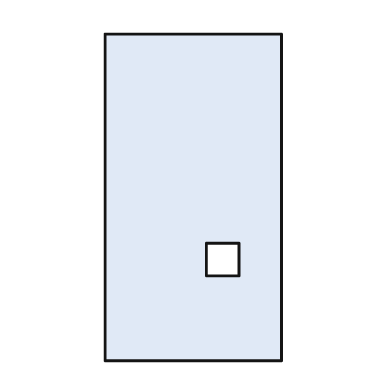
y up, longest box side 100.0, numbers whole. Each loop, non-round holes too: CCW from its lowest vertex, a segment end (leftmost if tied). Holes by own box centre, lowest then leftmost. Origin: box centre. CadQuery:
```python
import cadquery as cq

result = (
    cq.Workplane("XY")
    .moveTo(-27.0, -50.0)
    .lineTo(27.0, -50.0)
    .lineTo(27.0, 50.0)
    .lineTo(-27.0, 50.0)
    .close()
    .moveTo(4.0, -24.0)
    .lineTo(14.0, -24.0)
    .lineTo(14.0, -14.0)
    .lineTo(4.0, -14.0)
    .close()
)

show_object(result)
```